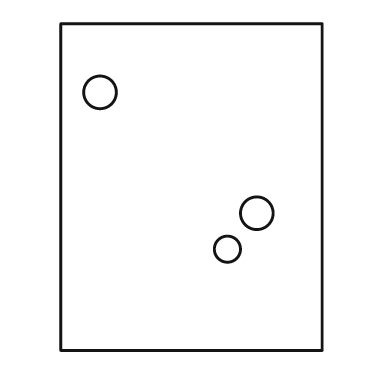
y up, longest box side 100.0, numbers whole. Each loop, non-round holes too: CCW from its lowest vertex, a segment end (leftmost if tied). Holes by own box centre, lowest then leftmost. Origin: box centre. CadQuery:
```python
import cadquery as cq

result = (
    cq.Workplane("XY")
    .moveTo(-40.0, -50.0)
    .lineTo(40.0, -50.0)
    .lineTo(40.0, 50.0)
    .lineTo(-40.0, 50.0)
    .close()
    .moveTo(11.0, -19.0)
    .circle(4.0)
    .moveTo(20.0, -8.0)
    .circle(5.0)
    .moveTo(-28.0, 29.0)
    .circle(5.0)
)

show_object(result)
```